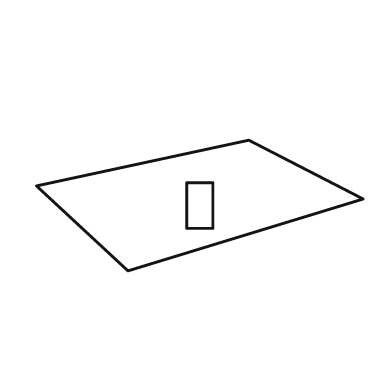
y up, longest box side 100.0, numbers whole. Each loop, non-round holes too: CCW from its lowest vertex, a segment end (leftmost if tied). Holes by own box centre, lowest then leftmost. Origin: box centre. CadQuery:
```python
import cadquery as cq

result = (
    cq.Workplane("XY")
    .moveTo(-22.0, -20.0)
    .lineTo(50.0, 2.0)
    .lineTo(15.0, 20.0)
    .lineTo(-50.0, 6.0)
    .close()
    .moveTo(-4.0, -7.0)
    .lineTo(4.0, -7.0)
    .lineTo(4.0, 7.0)
    .lineTo(-4.0, 7.0)
    .close()
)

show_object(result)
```